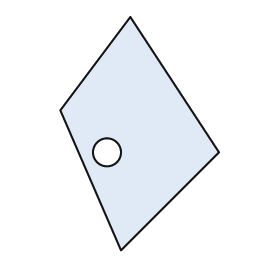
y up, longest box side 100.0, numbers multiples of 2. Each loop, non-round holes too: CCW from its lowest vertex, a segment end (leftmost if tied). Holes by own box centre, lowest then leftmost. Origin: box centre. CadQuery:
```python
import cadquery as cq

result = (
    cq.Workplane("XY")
    .moveTo(-8.0, -50.0)
    .lineTo(34.0, -8.0)
    .lineTo(-4.0, 50.0)
    .lineTo(-34.0, 10.0)
    .close()
    .moveTo(-14.0, -8.0)
    .circle(6.0)
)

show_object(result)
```